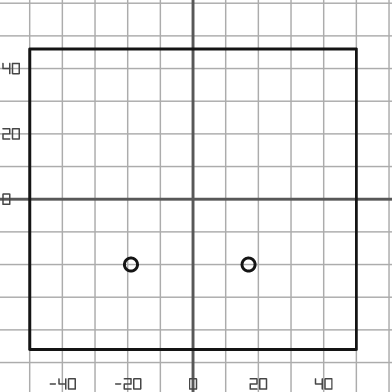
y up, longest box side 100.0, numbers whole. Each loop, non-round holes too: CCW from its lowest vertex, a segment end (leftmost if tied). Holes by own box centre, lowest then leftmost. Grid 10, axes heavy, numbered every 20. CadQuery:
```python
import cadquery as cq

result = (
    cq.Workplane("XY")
    .moveTo(-50.0, -46.0)
    .lineTo(50.0, -46.0)
    .lineTo(50.0, 46.0)
    .lineTo(-50.0, 46.0)
    .close()
    .moveTo(-19.0, -20.0)
    .circle(2.0)
    .moveTo(17.0, -20.0)
    .circle(2.0)
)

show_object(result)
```